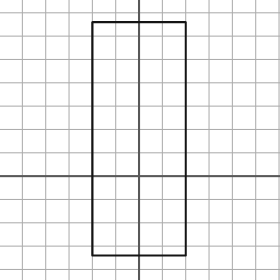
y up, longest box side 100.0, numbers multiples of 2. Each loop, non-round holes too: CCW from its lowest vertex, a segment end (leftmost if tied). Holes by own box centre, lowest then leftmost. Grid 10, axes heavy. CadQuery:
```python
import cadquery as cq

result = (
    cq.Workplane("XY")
    .moveTo(-20.0, -34.0)
    .lineTo(20.0, -34.0)
    .lineTo(20.0, 66.0)
    .lineTo(-20.0, 66.0)
    .close()
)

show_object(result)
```